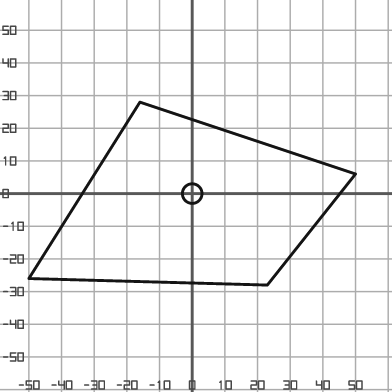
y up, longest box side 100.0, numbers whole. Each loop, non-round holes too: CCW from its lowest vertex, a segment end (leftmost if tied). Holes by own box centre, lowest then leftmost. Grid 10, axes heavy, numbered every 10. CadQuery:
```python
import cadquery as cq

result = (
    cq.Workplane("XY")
    .moveTo(23.0, -28.0)
    .lineTo(50.0, 6.0)
    .lineTo(-16.0, 28.0)
    .lineTo(-50.0, -26.0)
    .close()
    .moveTo(0.0, 0.0)
    .circle(3.0)
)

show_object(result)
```